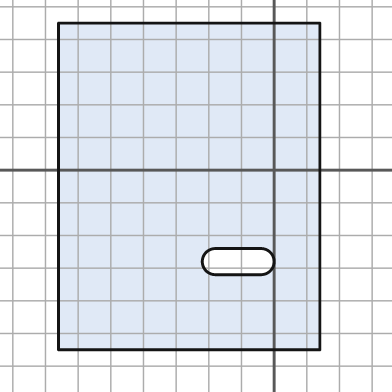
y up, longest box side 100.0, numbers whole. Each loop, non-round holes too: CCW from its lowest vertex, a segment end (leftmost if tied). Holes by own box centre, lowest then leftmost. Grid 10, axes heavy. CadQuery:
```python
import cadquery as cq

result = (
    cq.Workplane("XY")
    .moveTo(-66.0, -55.0)
    .lineTo(14.0, -55.0)
    .lineTo(14.0, 45.0)
    .lineTo(-66.0, 45.0)
    .close()
    .moveTo(-18.0, -32.0)
    .lineTo(-4.0, -32.0)
    .threePointArc((0.0, -28.0), (-4.0, -24.0))
    .lineTo(-18.0, -24.0)
    .threePointArc((-22.0, -28.0), (-18.0, -32.0))
    .close()
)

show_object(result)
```